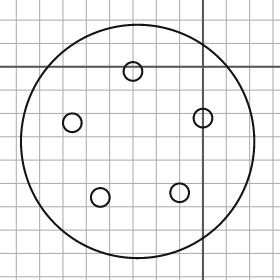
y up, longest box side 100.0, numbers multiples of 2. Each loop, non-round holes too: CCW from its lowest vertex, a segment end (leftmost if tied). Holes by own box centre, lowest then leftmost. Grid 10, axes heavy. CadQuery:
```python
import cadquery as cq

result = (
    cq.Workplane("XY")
    .moveTo(-28.0, -32.0)
    .circle(50.0)
    .moveTo(-44.0, -56.0)
    .circle(4.0)
    .moveTo(-10.0, -54.0)
    .circle(4.0)
    .moveTo(-56.0, -24.0)
    .circle(4.0)
    .moveTo(0.0, -22.0)
    .circle(4.0)
    .moveTo(-30.0, -2.0)
    .circle(4.0)
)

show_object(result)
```